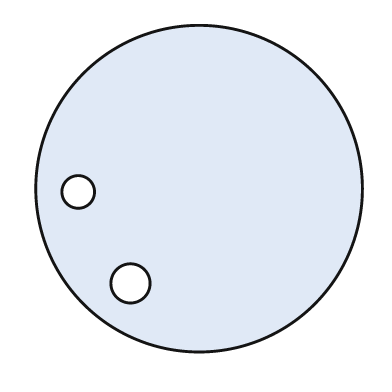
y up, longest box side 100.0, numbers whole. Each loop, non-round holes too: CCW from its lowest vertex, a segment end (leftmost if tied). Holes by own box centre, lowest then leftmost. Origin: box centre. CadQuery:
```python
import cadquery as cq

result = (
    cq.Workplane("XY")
    .moveTo(0.0, 0.0)
    .circle(50.0)
    .moveTo(-21.0, -29.0)
    .circle(6.0)
    .moveTo(-37.0, -1.0)
    .circle(5.0)
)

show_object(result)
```